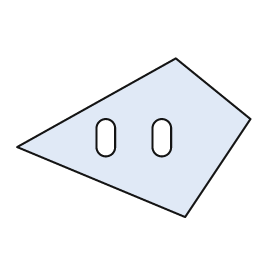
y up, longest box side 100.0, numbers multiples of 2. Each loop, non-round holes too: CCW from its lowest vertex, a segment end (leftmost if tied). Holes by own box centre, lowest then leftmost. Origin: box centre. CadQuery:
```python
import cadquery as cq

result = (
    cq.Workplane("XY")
    .moveTo(22.0, -34.0)
    .lineTo(50.0, 8.0)
    .lineTo(18.0, 34.0)
    .lineTo(-50.0, -4.0)
    .close()
    .moveTo(-16.0, -4.0)
    .threePointArc((-12.0, -8.0), (-8.0, -4.0))
    .lineTo(-8.0, 4.0)
    .threePointArc((-12.0, 8.0), (-16.0, 4.0))
    .close()
    .moveTo(8.0, -4.0)
    .threePointArc((12.0, -8.0), (16.0, -4.0))
    .lineTo(16.0, 4.0)
    .threePointArc((12.0, 8.0), (8.0, 4.0))
    .close()
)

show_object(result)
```